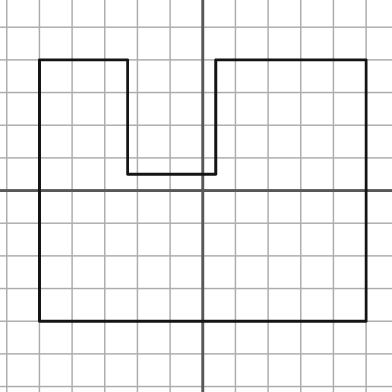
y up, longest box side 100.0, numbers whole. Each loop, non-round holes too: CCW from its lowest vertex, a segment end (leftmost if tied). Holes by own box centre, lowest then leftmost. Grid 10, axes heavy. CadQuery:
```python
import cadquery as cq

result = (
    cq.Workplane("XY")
    .moveTo(-50.0, -40.0)
    .lineTo(50.0, -40.0)
    .lineTo(50.0, 40.0)
    .lineTo(4.0, 40.0)
    .lineTo(4.0, 5.0)
    .lineTo(-23.0, 5.0)
    .lineTo(-23.0, 40.0)
    .lineTo(-50.0, 40.0)
    .close()
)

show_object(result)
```